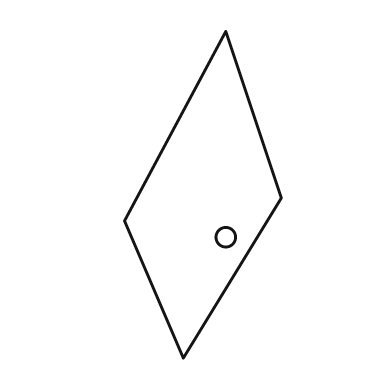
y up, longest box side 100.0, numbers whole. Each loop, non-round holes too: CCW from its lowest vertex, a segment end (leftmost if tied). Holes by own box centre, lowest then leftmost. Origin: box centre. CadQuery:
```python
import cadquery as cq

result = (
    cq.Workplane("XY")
    .moveTo(-6.0, -50.0)
    .lineTo(24.0, -1.0)
    .lineTo(7.0, 50.0)
    .lineTo(-24.0, -8.0)
    .close()
    .moveTo(7.0, -13.0)
    .circle(3.0)
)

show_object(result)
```